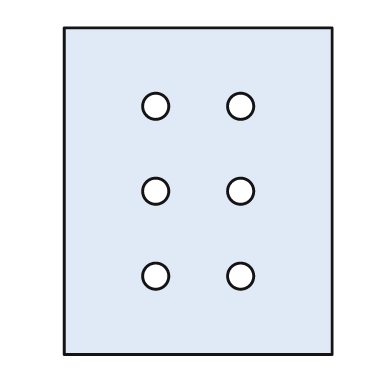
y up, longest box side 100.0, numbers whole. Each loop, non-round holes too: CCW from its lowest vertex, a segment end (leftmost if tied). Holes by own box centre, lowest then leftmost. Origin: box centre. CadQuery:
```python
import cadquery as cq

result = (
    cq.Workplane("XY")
    .moveTo(-41.0, -50.0)
    .lineTo(41.0, -50.0)
    .lineTo(41.0, 50.0)
    .lineTo(-41.0, 50.0)
    .close()
    .moveTo(-13.0, -26.0)
    .circle(4.0)
    .moveTo(13.0, -26.0)
    .circle(4.0)
    .moveTo(-13.0, 0.0)
    .circle(4.0)
    .moveTo(13.0, 0.0)
    .circle(4.0)
    .moveTo(-13.0, 26.0)
    .circle(4.0)
    .moveTo(13.0, 26.0)
    .circle(4.0)
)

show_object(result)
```